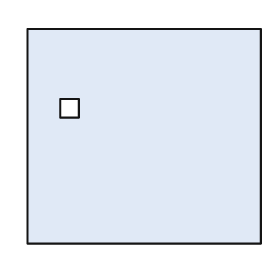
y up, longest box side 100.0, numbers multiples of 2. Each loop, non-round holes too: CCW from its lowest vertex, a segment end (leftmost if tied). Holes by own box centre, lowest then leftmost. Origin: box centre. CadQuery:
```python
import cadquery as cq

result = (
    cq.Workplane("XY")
    .moveTo(-50.0, -46.0)
    .lineTo(50.0, -46.0)
    .lineTo(50.0, 46.0)
    .lineTo(-50.0, 46.0)
    .close()
    .moveTo(-36.0, 8.0)
    .lineTo(-28.0, 8.0)
    .lineTo(-28.0, 16.0)
    .lineTo(-36.0, 16.0)
    .close()
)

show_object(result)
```